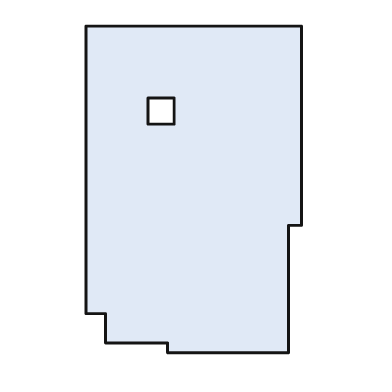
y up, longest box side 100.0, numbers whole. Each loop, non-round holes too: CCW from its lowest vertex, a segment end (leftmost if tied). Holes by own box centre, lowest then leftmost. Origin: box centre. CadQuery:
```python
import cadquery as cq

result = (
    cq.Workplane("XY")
    .moveTo(-8.0, -50.0)
    .lineTo(29.0, -50.0)
    .lineTo(29.0, -11.0)
    .lineTo(33.0, -11.0)
    .lineTo(33.0, 50.0)
    .lineTo(-33.0, 50.0)
    .lineTo(-33.0, -38.0)
    .lineTo(-27.0, -38.0)
    .lineTo(-27.0, -47.0)
    .lineTo(-8.0, -47.0)
    .close()
    .moveTo(-14.0, 20.0)
    .lineTo(-6.0, 20.0)
    .lineTo(-6.0, 28.0)
    .lineTo(-14.0, 28.0)
    .close()
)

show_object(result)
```